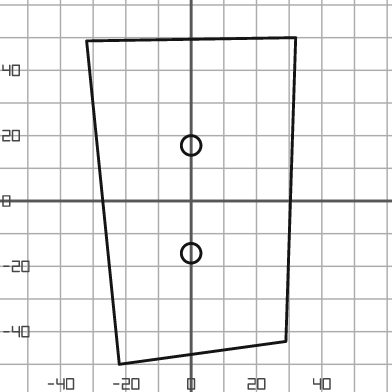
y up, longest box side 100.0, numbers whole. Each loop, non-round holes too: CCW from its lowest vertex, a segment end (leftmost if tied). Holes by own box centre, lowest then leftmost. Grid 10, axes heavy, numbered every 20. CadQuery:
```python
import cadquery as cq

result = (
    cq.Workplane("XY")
    .moveTo(-22.0, -50.0)
    .lineTo(29.0, -43.0)
    .lineTo(32.0, 50.0)
    .lineTo(-32.0, 49.0)
    .close()
    .moveTo(0.0, -16.0)
    .circle(3.0)
    .moveTo(0.0, 17.0)
    .circle(3.0)
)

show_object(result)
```